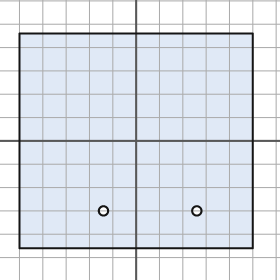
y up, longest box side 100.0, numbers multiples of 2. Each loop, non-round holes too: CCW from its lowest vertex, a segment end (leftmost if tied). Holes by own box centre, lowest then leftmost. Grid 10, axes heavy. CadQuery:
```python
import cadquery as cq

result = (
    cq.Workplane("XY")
    .moveTo(-50.0, -46.0)
    .lineTo(50.0, -46.0)
    .lineTo(50.0, 46.0)
    .lineTo(-50.0, 46.0)
    .close()
    .moveTo(-14.0, -30.0)
    .circle(2.0)
    .moveTo(26.0, -30.0)
    .circle(2.0)
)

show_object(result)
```